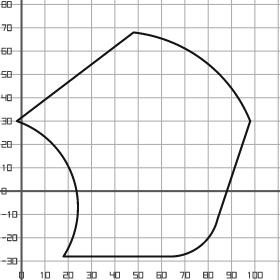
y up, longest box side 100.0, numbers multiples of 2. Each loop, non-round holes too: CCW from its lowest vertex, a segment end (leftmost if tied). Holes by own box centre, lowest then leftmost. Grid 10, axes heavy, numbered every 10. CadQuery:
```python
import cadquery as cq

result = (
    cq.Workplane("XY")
    .moveTo(18.0, -28.0)
    .lineTo(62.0, -28.0)
    .threePointArc((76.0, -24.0), (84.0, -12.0))
    .lineTo(98.0, 30.0)
    .threePointArc((78.0, 56.0), (48.0, 68.0))
    .lineTo(-2.0, 30.0)
    .threePointArc((22.0, 6.0), (18.0, -28.0))
    .close()
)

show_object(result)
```